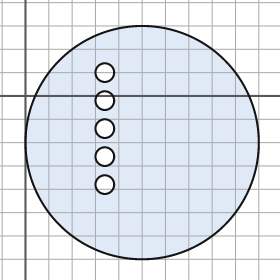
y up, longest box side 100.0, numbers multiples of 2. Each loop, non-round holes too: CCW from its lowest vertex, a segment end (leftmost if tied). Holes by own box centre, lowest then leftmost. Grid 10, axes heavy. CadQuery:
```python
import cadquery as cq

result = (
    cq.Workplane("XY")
    .moveTo(50.0, -20.0)
    .circle(50.0)
    .moveTo(34.0, -38.0)
    .circle(4.0)
    .moveTo(34.0, -26.0)
    .circle(4.0)
    .moveTo(34.0, -14.0)
    .circle(4.0)
    .moveTo(34.0, -2.0)
    .circle(4.0)
    .moveTo(34.0, 10.0)
    .circle(4.0)
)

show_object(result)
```